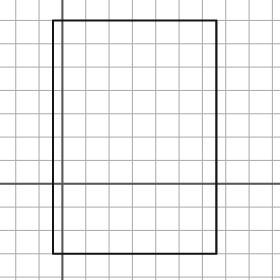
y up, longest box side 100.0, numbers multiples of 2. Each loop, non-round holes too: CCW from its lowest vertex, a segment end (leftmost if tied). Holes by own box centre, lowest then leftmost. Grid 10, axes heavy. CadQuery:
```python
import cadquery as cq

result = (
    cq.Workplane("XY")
    .moveTo(-4.0, -30.0)
    .lineTo(66.0, -30.0)
    .lineTo(66.0, 70.0)
    .lineTo(-4.0, 70.0)
    .close()
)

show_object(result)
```